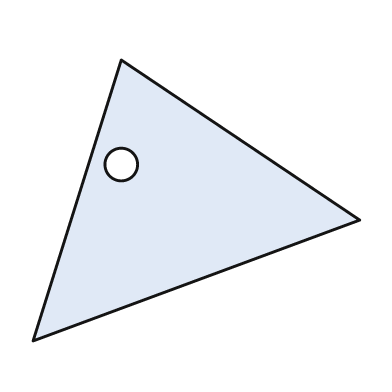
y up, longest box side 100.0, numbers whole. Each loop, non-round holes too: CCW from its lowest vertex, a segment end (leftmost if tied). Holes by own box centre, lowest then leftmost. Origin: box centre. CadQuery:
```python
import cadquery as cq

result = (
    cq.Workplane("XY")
    .moveTo(-50.0, -43.0)
    .lineTo(50.0, -6.0)
    .lineTo(-23.0, 43.0)
    .close()
    .moveTo(-23.0, 11.0)
    .circle(5.0)
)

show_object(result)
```